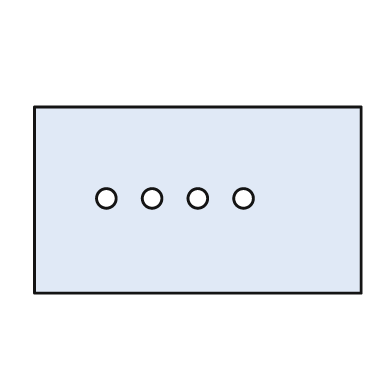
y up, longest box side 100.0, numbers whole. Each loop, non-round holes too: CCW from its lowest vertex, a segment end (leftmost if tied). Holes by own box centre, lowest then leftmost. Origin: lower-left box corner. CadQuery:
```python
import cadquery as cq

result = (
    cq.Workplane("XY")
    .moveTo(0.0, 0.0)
    .lineTo(100.0, 0.0)
    .lineTo(100.0, 57.0)
    .lineTo(0.0, 57.0)
    .close()
    .moveTo(22.0, 29.0)
    .circle(3.0)
    .moveTo(36.0, 29.0)
    .circle(3.0)
    .moveTo(50.0, 29.0)
    .circle(3.0)
    .moveTo(64.0, 29.0)
    .circle(3.0)
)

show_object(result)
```